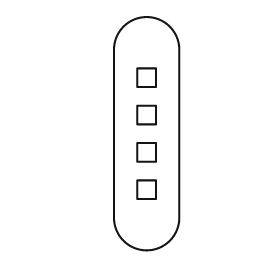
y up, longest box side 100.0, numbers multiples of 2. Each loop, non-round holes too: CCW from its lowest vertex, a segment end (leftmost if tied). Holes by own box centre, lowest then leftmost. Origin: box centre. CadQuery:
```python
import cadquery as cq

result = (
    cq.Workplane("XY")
    .moveTo(-14.0, -36.0)
    .threePointArc((0.0, -50.0), (14.0, -36.0))
    .lineTo(14.0, 36.0)
    .threePointArc((0.0, 50.0), (-14.0, 36.0))
    .close()
    .moveTo(-4.0, -28.0)
    .lineTo(4.0, -28.0)
    .lineTo(4.0, -20.0)
    .lineTo(-4.0, -20.0)
    .close()
    .moveTo(-4.0, -12.0)
    .lineTo(4.0, -12.0)
    .lineTo(4.0, -4.0)
    .lineTo(-4.0, -4.0)
    .close()
    .moveTo(-4.0, 4.0)
    .lineTo(4.0, 4.0)
    .lineTo(4.0, 12.0)
    .lineTo(-4.0, 12.0)
    .close()
    .moveTo(-4.0, 20.0)
    .lineTo(4.0, 20.0)
    .lineTo(4.0, 28.0)
    .lineTo(-4.0, 28.0)
    .close()
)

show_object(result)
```